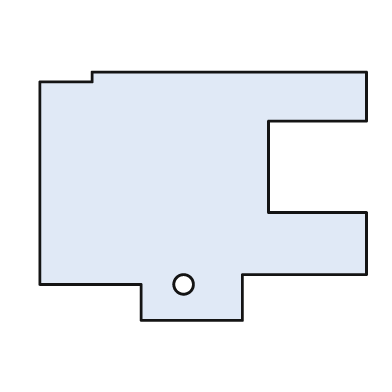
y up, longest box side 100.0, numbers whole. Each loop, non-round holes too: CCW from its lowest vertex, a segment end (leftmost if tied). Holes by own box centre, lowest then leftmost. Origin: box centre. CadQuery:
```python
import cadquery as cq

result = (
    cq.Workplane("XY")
    .moveTo(-19.0, -38.0)
    .lineTo(12.0, -38.0)
    .lineTo(12.0, -24.0)
    .lineTo(50.0, -24.0)
    .lineTo(50.0, -5.0)
    .lineTo(20.0, -5.0)
    .lineTo(20.0, 23.0)
    .lineTo(50.0, 23.0)
    .lineTo(50.0, 38.0)
    .lineTo(-34.0, 38.0)
    .lineTo(-34.0, 35.0)
    .lineTo(-50.0, 35.0)
    .lineTo(-50.0, -27.0)
    .lineTo(-19.0, -27.0)
    .close()
    .moveTo(-6.0, -27.0)
    .circle(3.0)
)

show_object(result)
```